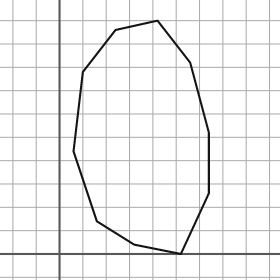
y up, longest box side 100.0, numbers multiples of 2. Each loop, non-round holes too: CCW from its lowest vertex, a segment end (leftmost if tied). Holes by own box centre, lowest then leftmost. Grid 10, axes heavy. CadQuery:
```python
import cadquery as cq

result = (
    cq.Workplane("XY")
    .moveTo(52.0, 0.0)
    .lineTo(64.0, 26.0)
    .lineTo(64.0, 52.0)
    .lineTo(56.0, 82.0)
    .lineTo(42.0, 100.0)
    .lineTo(24.0, 96.0)
    .lineTo(10.0, 78.0)
    .lineTo(6.0, 44.0)
    .lineTo(16.0, 14.0)
    .lineTo(32.0, 4.0)
    .close()
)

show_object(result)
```